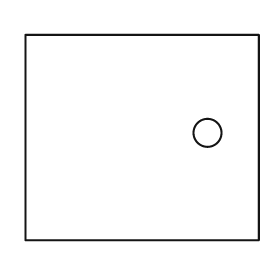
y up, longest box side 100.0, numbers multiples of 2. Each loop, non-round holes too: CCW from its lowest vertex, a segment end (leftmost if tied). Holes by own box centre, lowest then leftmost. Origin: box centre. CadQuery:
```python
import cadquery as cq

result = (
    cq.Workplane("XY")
    .moveTo(-50.0, -44.0)
    .lineTo(50.0, -44.0)
    .lineTo(50.0, 44.0)
    .lineTo(-50.0, 44.0)
    .close()
    .moveTo(28.0, 2.0)
    .circle(6.0)
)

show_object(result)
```